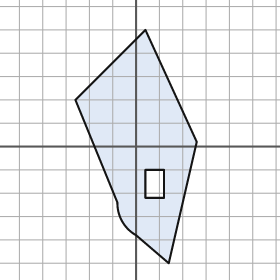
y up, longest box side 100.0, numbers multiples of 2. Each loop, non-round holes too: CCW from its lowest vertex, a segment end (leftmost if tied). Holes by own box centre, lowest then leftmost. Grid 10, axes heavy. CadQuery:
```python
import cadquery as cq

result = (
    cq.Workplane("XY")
    .moveTo(14.0, -50.0)
    .lineTo(26.0, 2.0)
    .lineTo(4.0, 50.0)
    .lineTo(-26.0, 20.0)
    .lineTo(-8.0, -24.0)
    .threePointArc((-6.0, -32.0), (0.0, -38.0))
    .close()
    .moveTo(4.0, -22.0)
    .lineTo(12.0, -22.0)
    .lineTo(12.0, -10.0)
    .lineTo(4.0, -10.0)
    .close()
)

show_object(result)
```